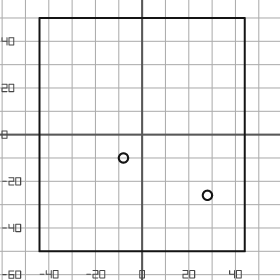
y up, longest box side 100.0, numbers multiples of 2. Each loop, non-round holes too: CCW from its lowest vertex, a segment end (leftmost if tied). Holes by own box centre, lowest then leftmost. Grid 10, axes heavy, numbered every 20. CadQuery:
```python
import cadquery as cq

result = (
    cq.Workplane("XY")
    .moveTo(-44.0, -50.0)
    .lineTo(44.0, -50.0)
    .lineTo(44.0, 50.0)
    .lineTo(-44.0, 50.0)
    .close()
    .moveTo(28.0, -26.0)
    .circle(2.0)
    .moveTo(-8.0, -10.0)
    .circle(2.0)
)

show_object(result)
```